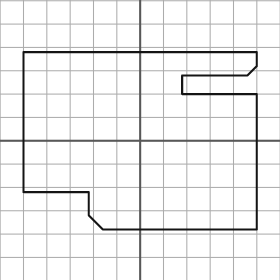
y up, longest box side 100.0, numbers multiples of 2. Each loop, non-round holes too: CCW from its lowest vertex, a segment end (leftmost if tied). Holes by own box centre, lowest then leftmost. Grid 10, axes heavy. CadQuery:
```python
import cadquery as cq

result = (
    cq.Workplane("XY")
    .moveTo(-16.0, -38.0)
    .lineTo(50.0, -38.0)
    .lineTo(50.0, 20.0)
    .lineTo(18.0, 20.0)
    .lineTo(18.0, 28.0)
    .lineTo(46.0, 28.0)
    .lineTo(50.0, 32.0)
    .lineTo(50.0, 38.0)
    .lineTo(-50.0, 38.0)
    .lineTo(-50.0, -22.0)
    .lineTo(-22.0, -22.0)
    .lineTo(-22.0, -32.0)
    .close()
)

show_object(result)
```